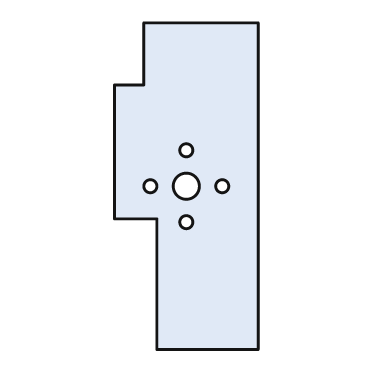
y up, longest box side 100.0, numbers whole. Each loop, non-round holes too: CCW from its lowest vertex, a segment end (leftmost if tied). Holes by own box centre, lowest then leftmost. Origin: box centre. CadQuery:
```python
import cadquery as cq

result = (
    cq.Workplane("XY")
    .moveTo(-9.0, -50.0)
    .lineTo(22.0, -50.0)
    .lineTo(22.0, 50.0)
    .lineTo(-13.0, 50.0)
    .lineTo(-13.0, 31.0)
    .lineTo(-22.0, 31.0)
    .lineTo(-22.0, -10.0)
    .lineTo(-9.0, -10.0)
    .close()
    .moveTo(0.0, -11.0)
    .circle(2.0)
    .moveTo(-11.0, 0.0)
    .circle(2.0)
    .moveTo(0.0, 0.0)
    .circle(4.0)
    .moveTo(11.0, 0.0)
    .circle(2.0)
    .moveTo(0.0, 11.0)
    .circle(2.0)
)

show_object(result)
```